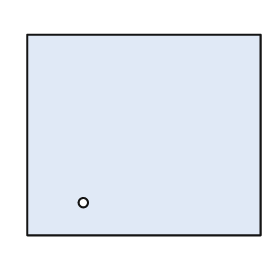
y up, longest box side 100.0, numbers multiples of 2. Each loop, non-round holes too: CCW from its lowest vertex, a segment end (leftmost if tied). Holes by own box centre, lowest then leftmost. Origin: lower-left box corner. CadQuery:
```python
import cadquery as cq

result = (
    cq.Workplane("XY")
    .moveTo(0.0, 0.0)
    .lineTo(100.0, 0.0)
    .lineTo(100.0, 86.0)
    .lineTo(0.0, 86.0)
    .close()
    .moveTo(24.0, 14.0)
    .circle(2.0)
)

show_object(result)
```